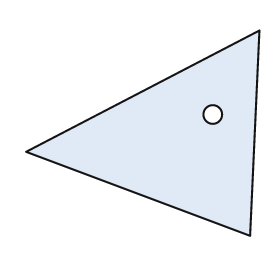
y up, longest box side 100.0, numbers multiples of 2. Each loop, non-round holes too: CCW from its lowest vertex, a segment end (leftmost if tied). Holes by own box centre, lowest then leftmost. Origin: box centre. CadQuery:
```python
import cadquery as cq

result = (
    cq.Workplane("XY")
    .moveTo(46.0, -44.0)
    .lineTo(50.0, 44.0)
    .lineTo(-50.0, -8.0)
    .close()
    .moveTo(30.0, 8.0)
    .circle(4.0)
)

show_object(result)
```